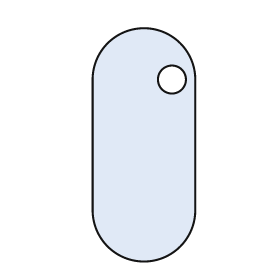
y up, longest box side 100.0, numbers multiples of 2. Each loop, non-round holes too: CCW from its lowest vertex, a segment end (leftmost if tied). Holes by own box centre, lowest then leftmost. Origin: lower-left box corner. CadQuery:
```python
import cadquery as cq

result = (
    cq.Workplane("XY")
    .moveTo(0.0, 22.0)
    .threePointArc((22.0, 0.0), (44.0, 22.0))
    .lineTo(44.0, 78.0)
    .threePointArc((22.0, 100.0), (0.0, 78.0))
    .close()
    .moveTo(34.0, 78.0)
    .circle(6.0)
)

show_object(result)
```